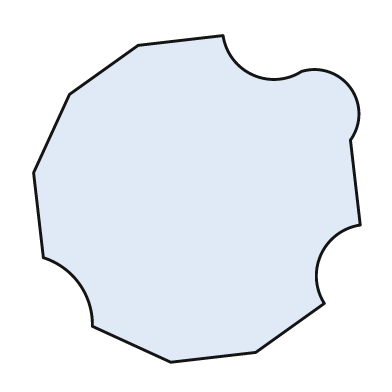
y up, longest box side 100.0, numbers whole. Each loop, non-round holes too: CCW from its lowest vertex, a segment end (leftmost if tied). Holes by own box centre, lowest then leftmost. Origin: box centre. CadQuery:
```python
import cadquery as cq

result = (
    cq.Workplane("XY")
    .moveTo(-8.0, -50.0)
    .lineTo(18.0, -47.0)
    .lineTo(39.0, -32.0)
    .threePointArc((38.0, -17.0), (50.0, -8.0))
    .lineTo(47.0, 18.0)
    .threePointArc((47.0, 34.0), (32.0, 39.0))
    .threePointArc((17.0, 38.0), (8.0, 50.0))
    .lineTo(-18.0, 47.0)
    .lineTo(-39.0, 32.0)
    .lineTo(-50.0, 8.0)
    .lineTo(-47.0, -18.0)
    .threePointArc((-36.0, -26.0), (-32.0, -39.0))
    .close()
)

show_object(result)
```